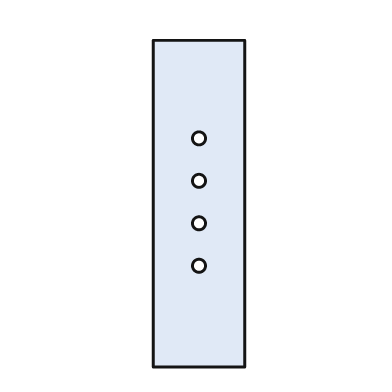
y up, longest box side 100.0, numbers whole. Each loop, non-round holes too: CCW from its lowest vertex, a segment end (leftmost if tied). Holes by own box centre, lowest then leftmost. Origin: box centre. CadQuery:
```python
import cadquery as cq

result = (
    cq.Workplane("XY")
    .moveTo(-14.0, -50.0)
    .lineTo(14.0, -50.0)
    .lineTo(14.0, 50.0)
    .lineTo(-14.0, 50.0)
    .close()
    .moveTo(0.0, -19.0)
    .circle(2.0)
    .moveTo(0.0, -6.0)
    .circle(2.0)
    .moveTo(0.0, 7.0)
    .circle(2.0)
    .moveTo(0.0, 20.0)
    .circle(2.0)
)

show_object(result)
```